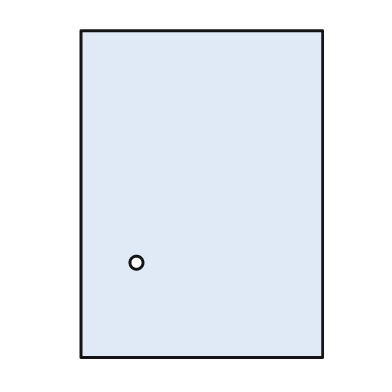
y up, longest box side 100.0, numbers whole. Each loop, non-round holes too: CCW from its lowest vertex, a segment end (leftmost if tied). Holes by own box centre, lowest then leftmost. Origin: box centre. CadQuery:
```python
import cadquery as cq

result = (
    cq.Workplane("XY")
    .moveTo(-37.0, -50.0)
    .lineTo(37.0, -50.0)
    .lineTo(37.0, 50.0)
    .lineTo(-37.0, 50.0)
    .close()
    .moveTo(-20.0, -21.0)
    .circle(2.0)
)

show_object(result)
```